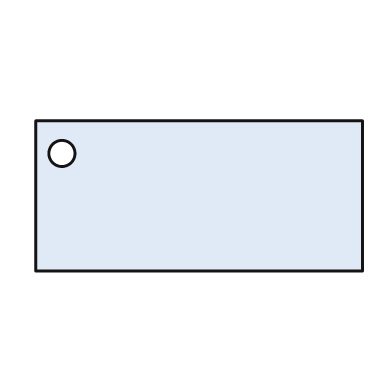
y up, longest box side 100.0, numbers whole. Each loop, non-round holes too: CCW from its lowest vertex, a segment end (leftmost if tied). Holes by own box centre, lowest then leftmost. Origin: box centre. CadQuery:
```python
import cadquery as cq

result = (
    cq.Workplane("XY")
    .moveTo(-50.0, -23.0)
    .lineTo(50.0, -23.0)
    .lineTo(50.0, 23.0)
    .lineTo(-50.0, 23.0)
    .close()
    .moveTo(-42.0, 13.0)
    .circle(4.0)
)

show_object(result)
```